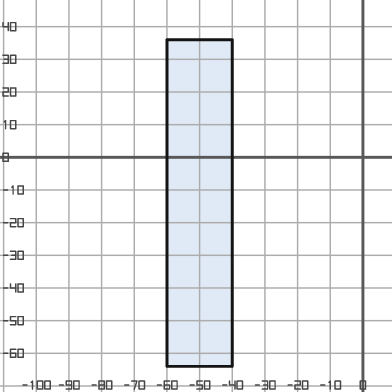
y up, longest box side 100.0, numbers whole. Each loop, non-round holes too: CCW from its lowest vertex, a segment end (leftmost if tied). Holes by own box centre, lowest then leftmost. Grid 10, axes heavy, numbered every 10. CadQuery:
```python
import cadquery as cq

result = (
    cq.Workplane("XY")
    .moveTo(-60.0, -64.0)
    .lineTo(-40.0, -64.0)
    .lineTo(-40.0, 36.0)
    .lineTo(-60.0, 36.0)
    .close()
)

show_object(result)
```